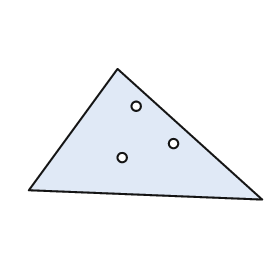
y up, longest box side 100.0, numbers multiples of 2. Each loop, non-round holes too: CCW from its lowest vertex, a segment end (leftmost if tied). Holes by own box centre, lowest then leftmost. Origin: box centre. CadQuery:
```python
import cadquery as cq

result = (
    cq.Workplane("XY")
    .moveTo(50.0, -28.0)
    .lineTo(-12.0, 28.0)
    .lineTo(-50.0, -24.0)
    .close()
    .moveTo(-10.0, -10.0)
    .circle(2.0)
    .moveTo(12.0, -4.0)
    .circle(2.0)
    .moveTo(-4.0, 12.0)
    .circle(2.0)
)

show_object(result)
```